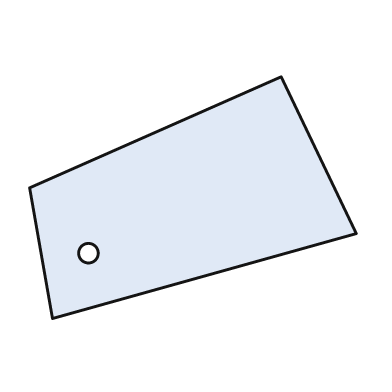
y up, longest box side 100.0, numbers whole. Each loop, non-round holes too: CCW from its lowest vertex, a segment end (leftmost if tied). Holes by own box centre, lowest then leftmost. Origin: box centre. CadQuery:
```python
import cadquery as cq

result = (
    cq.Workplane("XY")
    .moveTo(-43.0, -37.0)
    .lineTo(50.0, -11.0)
    .lineTo(27.0, 37.0)
    .lineTo(-50.0, 3.0)
    .close()
    .moveTo(-32.0, -17.0)
    .circle(3.0)
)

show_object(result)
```